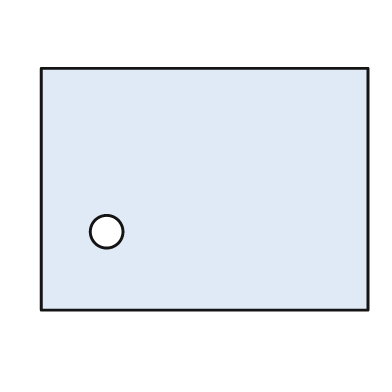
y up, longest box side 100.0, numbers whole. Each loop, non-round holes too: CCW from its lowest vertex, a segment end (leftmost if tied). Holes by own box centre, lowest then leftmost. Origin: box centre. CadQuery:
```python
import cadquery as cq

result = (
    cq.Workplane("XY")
    .moveTo(-50.0, -37.0)
    .lineTo(50.0, -37.0)
    .lineTo(50.0, 37.0)
    .lineTo(-50.0, 37.0)
    .close()
    .moveTo(-30.0, -13.0)
    .circle(5.0)
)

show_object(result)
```